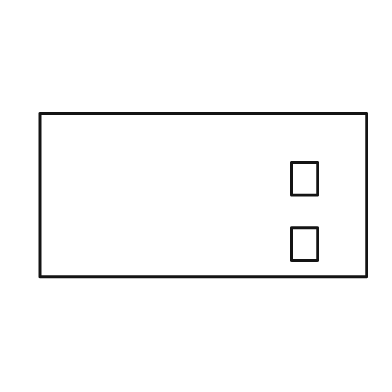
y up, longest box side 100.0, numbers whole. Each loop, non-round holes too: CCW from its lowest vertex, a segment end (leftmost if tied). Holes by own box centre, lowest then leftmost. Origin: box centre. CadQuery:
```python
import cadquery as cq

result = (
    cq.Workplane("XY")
    .moveTo(-50.0, -25.0)
    .lineTo(50.0, -25.0)
    .lineTo(50.0, 25.0)
    .lineTo(-50.0, 25.0)
    .close()
    .moveTo(27.0, -20.0)
    .lineTo(35.0, -20.0)
    .lineTo(35.0, -10.0)
    .lineTo(27.0, -10.0)
    .close()
    .moveTo(27.0, 0.0)
    .lineTo(35.0, 0.0)
    .lineTo(35.0, 10.0)
    .lineTo(27.0, 10.0)
    .close()
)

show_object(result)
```